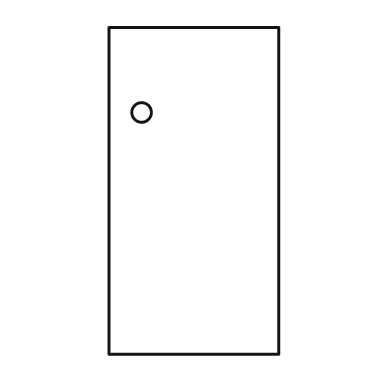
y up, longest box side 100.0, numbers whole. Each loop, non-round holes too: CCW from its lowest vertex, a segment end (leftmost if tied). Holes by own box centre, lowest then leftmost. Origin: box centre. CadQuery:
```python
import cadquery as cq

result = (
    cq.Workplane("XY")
    .moveTo(-26.0, -50.0)
    .lineTo(26.0, -50.0)
    .lineTo(26.0, 50.0)
    .lineTo(-26.0, 50.0)
    .close()
    .moveTo(-16.0, 24.0)
    .circle(3.0)
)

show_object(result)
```